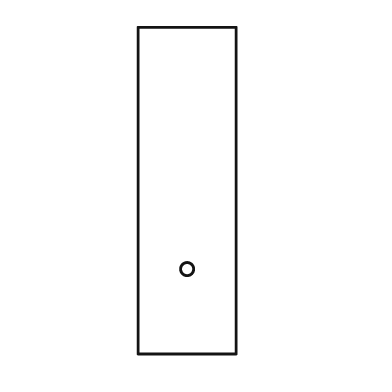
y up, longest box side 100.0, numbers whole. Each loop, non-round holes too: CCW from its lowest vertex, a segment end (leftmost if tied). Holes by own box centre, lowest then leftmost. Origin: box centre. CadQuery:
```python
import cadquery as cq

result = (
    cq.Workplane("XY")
    .moveTo(-15.0, -50.0)
    .lineTo(15.0, -50.0)
    .lineTo(15.0, 50.0)
    .lineTo(-15.0, 50.0)
    .close()
    .moveTo(0.0, -24.0)
    .circle(2.0)
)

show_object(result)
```